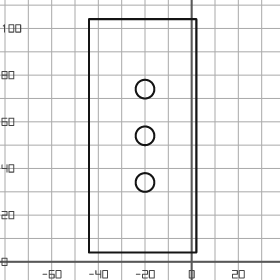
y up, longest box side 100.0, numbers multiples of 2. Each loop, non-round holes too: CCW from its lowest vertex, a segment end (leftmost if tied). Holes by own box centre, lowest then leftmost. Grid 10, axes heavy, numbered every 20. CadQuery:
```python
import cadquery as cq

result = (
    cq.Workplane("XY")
    .moveTo(-44.0, 4.0)
    .lineTo(2.0, 4.0)
    .lineTo(2.0, 104.0)
    .lineTo(-44.0, 104.0)
    .close()
    .moveTo(-20.0, 34.0)
    .circle(4.0)
    .moveTo(-20.0, 54.0)
    .circle(4.0)
    .moveTo(-20.0, 74.0)
    .circle(4.0)
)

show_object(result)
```